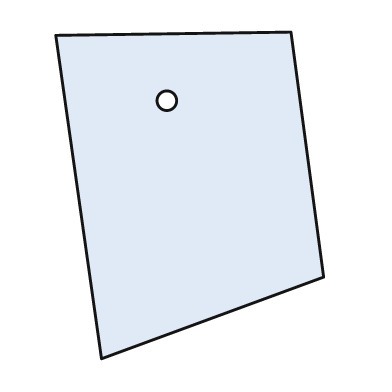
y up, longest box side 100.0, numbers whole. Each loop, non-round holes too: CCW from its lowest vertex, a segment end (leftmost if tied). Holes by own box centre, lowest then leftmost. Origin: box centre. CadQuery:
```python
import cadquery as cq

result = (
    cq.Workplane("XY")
    .moveTo(-27.0, -50.0)
    .lineTo(41.0, -25.0)
    .lineTo(31.0, 50.0)
    .lineTo(-41.0, 49.0)
    .close()
    .moveTo(-7.0, 29.0)
    .circle(3.0)
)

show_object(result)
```